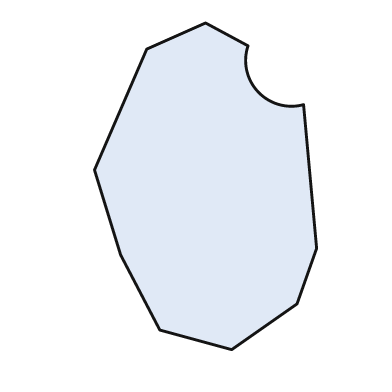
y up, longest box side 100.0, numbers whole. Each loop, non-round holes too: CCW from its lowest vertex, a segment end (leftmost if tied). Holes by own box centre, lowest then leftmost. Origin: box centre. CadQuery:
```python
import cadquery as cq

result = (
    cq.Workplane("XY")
    .moveTo(8.0, -50.0)
    .lineTo(28.0, -36.0)
    .lineTo(34.0, -19.0)
    .lineTo(30.0, 25.0)
    .threePointArc((16.0, 29.0), (13.0, 43.0))
    .lineTo(0.0, 50.0)
    .lineTo(-18.0, 42.0)
    .lineTo(-34.0, 5.0)
    .lineTo(-26.0, -21.0)
    .lineTo(-14.0, -44.0)
    .close()
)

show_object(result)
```